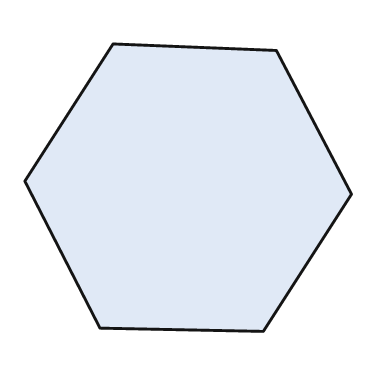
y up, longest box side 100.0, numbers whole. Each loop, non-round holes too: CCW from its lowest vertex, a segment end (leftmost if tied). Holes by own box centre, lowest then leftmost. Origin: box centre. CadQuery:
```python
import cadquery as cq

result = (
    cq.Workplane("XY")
    .moveTo(23.0, -44.0)
    .lineTo(50.0, -2.0)
    .lineTo(27.0, 42.0)
    .lineTo(-23.0, 44.0)
    .lineTo(-50.0, 2.0)
    .lineTo(-27.0, -43.0)
    .close()
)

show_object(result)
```